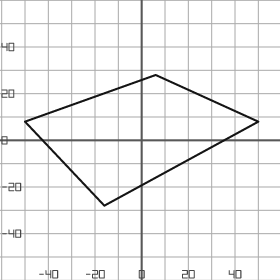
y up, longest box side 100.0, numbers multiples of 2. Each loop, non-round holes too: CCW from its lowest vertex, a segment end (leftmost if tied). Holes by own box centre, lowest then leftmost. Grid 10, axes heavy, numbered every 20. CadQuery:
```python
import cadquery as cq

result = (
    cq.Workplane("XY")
    .moveTo(-16.0, -28.0)
    .lineTo(50.0, 8.0)
    .lineTo(6.0, 28.0)
    .lineTo(-50.0, 8.0)
    .close()
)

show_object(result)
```